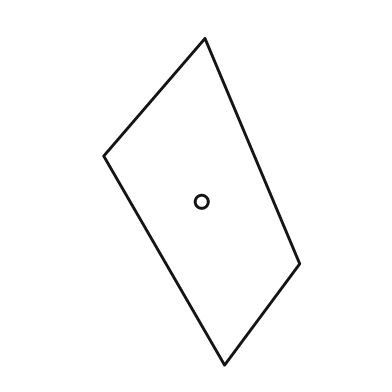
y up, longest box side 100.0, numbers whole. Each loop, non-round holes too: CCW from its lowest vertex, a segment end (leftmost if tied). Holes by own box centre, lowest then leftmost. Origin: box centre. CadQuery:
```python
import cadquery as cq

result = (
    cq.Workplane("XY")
    .moveTo(7.0, -50.0)
    .lineTo(30.0, -19.0)
    .lineTo(1.0, 50.0)
    .lineTo(-30.0, 14.0)
    .close()
    .moveTo(0.0, 0.0)
    .circle(2.0)
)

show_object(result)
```